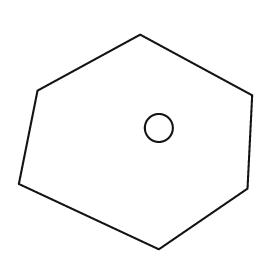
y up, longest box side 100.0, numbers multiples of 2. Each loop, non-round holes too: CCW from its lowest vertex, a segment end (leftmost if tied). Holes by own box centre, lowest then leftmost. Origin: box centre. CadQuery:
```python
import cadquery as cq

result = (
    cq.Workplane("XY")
    .moveTo(10.0, -46.0)
    .lineTo(48.0, -20.0)
    .lineTo(50.0, 20.0)
    .lineTo(2.0, 46.0)
    .lineTo(-42.0, 22.0)
    .lineTo(-50.0, -18.0)
    .close()
    .moveTo(10.0, 6.0)
    .circle(6.0)
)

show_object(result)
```